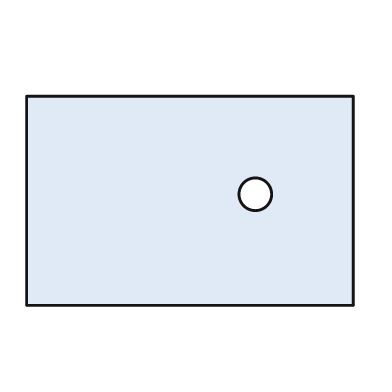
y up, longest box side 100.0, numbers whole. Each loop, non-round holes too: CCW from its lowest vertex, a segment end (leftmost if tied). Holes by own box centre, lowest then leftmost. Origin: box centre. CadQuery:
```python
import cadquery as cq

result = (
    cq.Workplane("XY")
    .moveTo(-50.0, -32.0)
    .lineTo(50.0, -32.0)
    .lineTo(50.0, 32.0)
    .lineTo(-50.0, 32.0)
    .close()
    .moveTo(20.0, 2.0)
    .circle(5.0)
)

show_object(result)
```